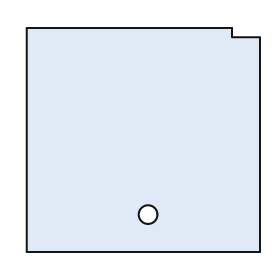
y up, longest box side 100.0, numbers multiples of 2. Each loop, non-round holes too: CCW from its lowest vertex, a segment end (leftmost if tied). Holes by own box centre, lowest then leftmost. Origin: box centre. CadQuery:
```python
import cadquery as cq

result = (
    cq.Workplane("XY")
    .moveTo(-50.0, -48.0)
    .lineTo(50.0, -48.0)
    .lineTo(50.0, 44.0)
    .lineTo(38.0, 44.0)
    .lineTo(38.0, 48.0)
    .lineTo(-50.0, 48.0)
    .close()
    .moveTo(2.0, -32.0)
    .circle(4.0)
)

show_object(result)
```